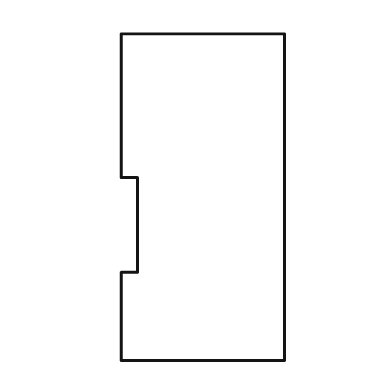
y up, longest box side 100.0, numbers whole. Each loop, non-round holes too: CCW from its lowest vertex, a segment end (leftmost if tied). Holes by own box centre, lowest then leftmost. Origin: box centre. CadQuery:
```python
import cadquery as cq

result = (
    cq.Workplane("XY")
    .moveTo(-25.0, -50.0)
    .lineTo(25.0, -50.0)
    .lineTo(25.0, 50.0)
    .lineTo(-25.0, 50.0)
    .lineTo(-25.0, 6.0)
    .lineTo(-20.0, 6.0)
    .lineTo(-20.0, -23.0)
    .lineTo(-25.0, -23.0)
    .close()
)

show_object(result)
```